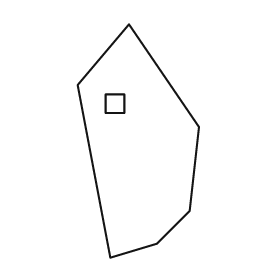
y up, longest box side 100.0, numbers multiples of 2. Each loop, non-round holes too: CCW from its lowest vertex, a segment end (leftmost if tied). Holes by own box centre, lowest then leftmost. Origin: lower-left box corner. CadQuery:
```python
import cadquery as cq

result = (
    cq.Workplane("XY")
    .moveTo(14.0, 0.0)
    .lineTo(34.0, 6.0)
    .lineTo(48.0, 20.0)
    .lineTo(52.0, 56.0)
    .lineTo(22.0, 100.0)
    .lineTo(0.0, 74.0)
    .close()
    .moveTo(12.0, 62.0)
    .lineTo(20.0, 62.0)
    .lineTo(20.0, 70.0)
    .lineTo(12.0, 70.0)
    .close()
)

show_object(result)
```